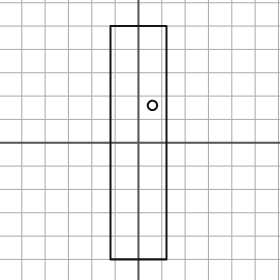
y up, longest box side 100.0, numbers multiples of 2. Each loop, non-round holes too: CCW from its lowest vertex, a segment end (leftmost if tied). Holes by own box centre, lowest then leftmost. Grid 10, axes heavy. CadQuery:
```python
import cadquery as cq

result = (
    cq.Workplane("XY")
    .moveTo(-12.0, -50.0)
    .lineTo(12.0, -50.0)
    .lineTo(12.0, 50.0)
    .lineTo(-12.0, 50.0)
    .close()
    .moveTo(6.0, 16.0)
    .circle(2.0)
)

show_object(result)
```